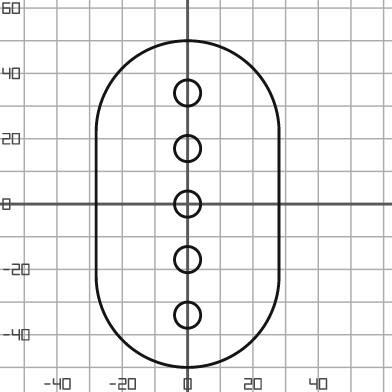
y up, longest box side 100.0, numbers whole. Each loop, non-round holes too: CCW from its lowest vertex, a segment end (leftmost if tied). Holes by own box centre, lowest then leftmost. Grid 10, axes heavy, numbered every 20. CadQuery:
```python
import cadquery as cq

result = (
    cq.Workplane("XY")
    .moveTo(-28.0, -22.0)
    .threePointArc((0.0, -50.0), (28.0, -22.0))
    .lineTo(28.0, 22.0)
    .threePointArc((0.0, 50.0), (-28.0, 22.0))
    .close()
    .moveTo(0.0, -34.0)
    .circle(4.0)
    .moveTo(0.0, -17.0)
    .circle(4.0)
    .moveTo(0.0, 0.0)
    .circle(4.0)
    .moveTo(0.0, 17.0)
    .circle(4.0)
    .moveTo(0.0, 34.0)
    .circle(4.0)
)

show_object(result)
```